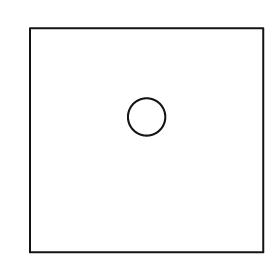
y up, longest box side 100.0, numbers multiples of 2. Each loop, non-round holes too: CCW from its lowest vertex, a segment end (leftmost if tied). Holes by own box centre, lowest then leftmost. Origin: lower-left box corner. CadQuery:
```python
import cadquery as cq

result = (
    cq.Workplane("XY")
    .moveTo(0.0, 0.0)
    .lineTo(100.0, 0.0)
    .lineTo(100.0, 96.0)
    .lineTo(0.0, 96.0)
    .close()
    .moveTo(50.0, 58.0)
    .circle(8.0)
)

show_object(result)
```